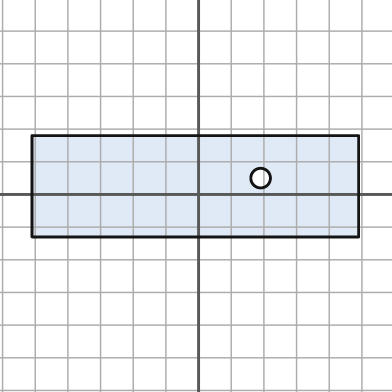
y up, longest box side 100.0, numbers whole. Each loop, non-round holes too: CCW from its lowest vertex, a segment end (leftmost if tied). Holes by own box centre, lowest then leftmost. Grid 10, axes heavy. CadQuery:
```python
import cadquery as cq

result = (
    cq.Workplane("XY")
    .moveTo(-51.0, -13.0)
    .lineTo(49.0, -13.0)
    .lineTo(49.0, 18.0)
    .lineTo(-51.0, 18.0)
    .close()
    .moveTo(19.0, 5.0)
    .circle(3.0)
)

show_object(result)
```